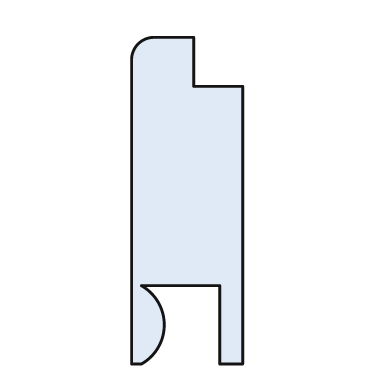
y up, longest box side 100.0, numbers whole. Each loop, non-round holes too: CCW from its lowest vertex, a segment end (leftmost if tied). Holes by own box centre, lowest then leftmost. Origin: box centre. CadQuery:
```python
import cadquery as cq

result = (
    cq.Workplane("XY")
    .moveTo(-17.0, -50.0)
    .lineTo(-14.0, -50.0)
    .threePointArc((-7.0, -38.0), (-14.0, -26.0))
    .lineTo(10.0, -26.0)
    .lineTo(10.0, -50.0)
    .lineTo(17.0, -50.0)
    .lineTo(17.0, 35.0)
    .lineTo(2.0, 35.0)
    .lineTo(2.0, 50.0)
    .lineTo(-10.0, 50.0)
    .threePointArc((-15.0, 48.0), (-17.0, 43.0))
    .close()
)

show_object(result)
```